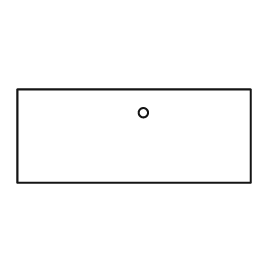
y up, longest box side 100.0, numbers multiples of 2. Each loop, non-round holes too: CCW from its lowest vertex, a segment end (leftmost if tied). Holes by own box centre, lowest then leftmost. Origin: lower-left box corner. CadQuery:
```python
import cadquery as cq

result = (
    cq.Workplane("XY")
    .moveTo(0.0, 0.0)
    .lineTo(100.0, 0.0)
    .lineTo(100.0, 40.0)
    .lineTo(0.0, 40.0)
    .close()
    .moveTo(54.0, 30.0)
    .circle(2.0)
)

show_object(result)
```